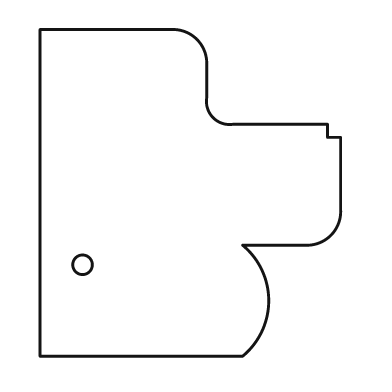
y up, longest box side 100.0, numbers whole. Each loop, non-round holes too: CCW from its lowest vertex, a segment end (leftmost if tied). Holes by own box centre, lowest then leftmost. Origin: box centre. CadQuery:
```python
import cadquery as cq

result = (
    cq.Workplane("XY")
    .moveTo(-46.0, -50.0)
    .lineTo(16.0, -50.0)
    .threePointArc((24.0, -33.0), (16.0, -16.0))
    .lineTo(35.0, -16.0)
    .threePointArc((43.0, -13.0), (46.0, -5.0))
    .lineTo(46.0, 17.0)
    .lineTo(42.0, 17.0)
    .lineTo(42.0, 21.0)
    .lineTo(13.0, 21.0)
    .threePointArc((7.0, 23.0), (5.0, 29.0))
    .lineTo(5.0, 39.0)
    .threePointArc((2.0, 47.0), (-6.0, 50.0))
    .lineTo(-46.0, 50.0)
    .close()
    .moveTo(-33.0, -22.0)
    .circle(3.0)
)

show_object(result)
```